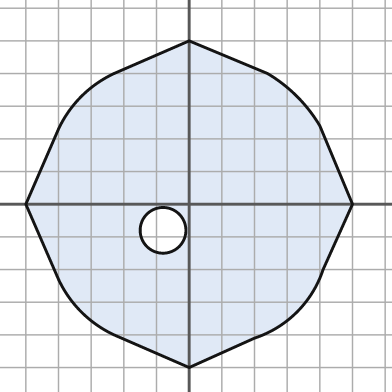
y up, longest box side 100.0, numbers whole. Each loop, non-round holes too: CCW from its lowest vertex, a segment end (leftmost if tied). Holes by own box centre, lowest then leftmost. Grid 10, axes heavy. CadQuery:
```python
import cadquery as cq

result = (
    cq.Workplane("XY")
    .moveTo(0.0, -50.0)
    .lineTo(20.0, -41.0)
    .threePointArc((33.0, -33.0), (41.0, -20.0))
    .lineTo(50.0, 0.0)
    .lineTo(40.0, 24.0)
    .threePointArc((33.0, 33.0), (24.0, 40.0))
    .lineTo(0.0, 50.0)
    .lineTo(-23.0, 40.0)
    .threePointArc((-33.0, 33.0), (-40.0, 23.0))
    .lineTo(-50.0, 0.0)
    .lineTo(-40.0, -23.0)
    .threePointArc((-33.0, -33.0), (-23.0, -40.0))
    .close()
    .moveTo(-8.0, -8.0)
    .circle(7.0)
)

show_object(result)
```